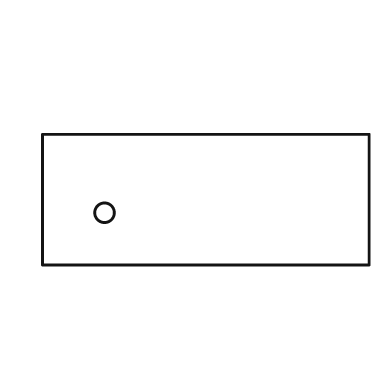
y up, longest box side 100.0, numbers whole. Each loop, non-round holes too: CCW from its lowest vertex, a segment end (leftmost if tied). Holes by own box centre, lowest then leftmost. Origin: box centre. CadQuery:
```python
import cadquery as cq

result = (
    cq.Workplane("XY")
    .moveTo(-50.0, -20.0)
    .lineTo(50.0, -20.0)
    .lineTo(50.0, 20.0)
    .lineTo(-50.0, 20.0)
    .close()
    .moveTo(-31.0, -4.0)
    .circle(3.0)
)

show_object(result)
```